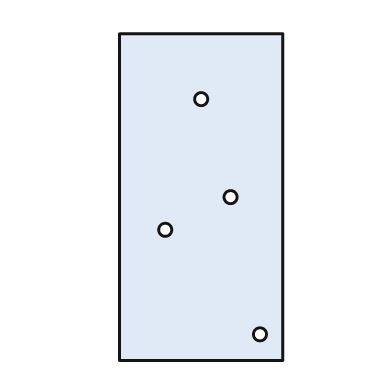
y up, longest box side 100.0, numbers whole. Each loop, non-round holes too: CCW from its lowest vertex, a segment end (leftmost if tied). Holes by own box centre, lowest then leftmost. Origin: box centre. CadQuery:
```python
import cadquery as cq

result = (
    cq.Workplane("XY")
    .moveTo(-25.0, -50.0)
    .lineTo(25.0, -50.0)
    .lineTo(25.0, 50.0)
    .lineTo(-25.0, 50.0)
    .close()
    .moveTo(18.0, -42.0)
    .circle(2.0)
    .moveTo(-11.0, -10.0)
    .circle(2.0)
    .moveTo(9.0, 0.0)
    .circle(2.0)
    .moveTo(0.0, 30.0)
    .circle(2.0)
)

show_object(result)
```